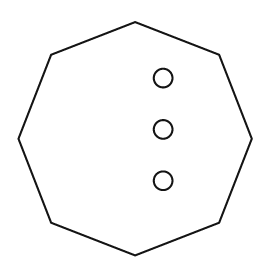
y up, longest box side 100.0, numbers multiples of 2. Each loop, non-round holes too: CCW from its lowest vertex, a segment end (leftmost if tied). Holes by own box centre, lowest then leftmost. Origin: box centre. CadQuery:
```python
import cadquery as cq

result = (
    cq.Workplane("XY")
    .moveTo(0.0, -50.0)
    .lineTo(36.0, -36.0)
    .lineTo(50.0, 0.0)
    .lineTo(36.0, 36.0)
    .lineTo(0.0, 50.0)
    .lineTo(-36.0, 36.0)
    .lineTo(-50.0, 0.0)
    .lineTo(-36.0, -36.0)
    .close()
    .moveTo(12.0, -18.0)
    .circle(4.0)
    .moveTo(12.0, 4.0)
    .circle(4.0)
    .moveTo(12.0, 26.0)
    .circle(4.0)
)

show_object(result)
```